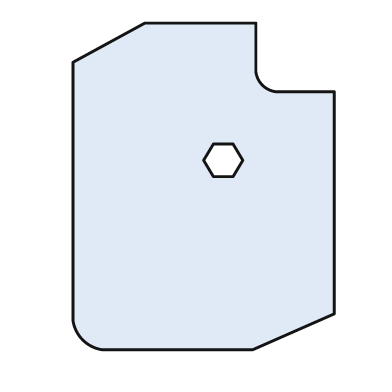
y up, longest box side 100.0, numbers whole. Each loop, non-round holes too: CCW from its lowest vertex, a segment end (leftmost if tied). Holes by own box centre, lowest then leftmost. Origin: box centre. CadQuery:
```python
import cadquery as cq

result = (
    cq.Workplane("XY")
    .moveTo(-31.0, -50.0)
    .lineTo(15.0, -50.0)
    .lineTo(40.0, -39.0)
    .lineTo(40.0, 29.0)
    .lineTo(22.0, 29.0)
    .threePointArc((18.0, 31.0), (16.0, 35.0))
    .lineTo(16.0, 50.0)
    .lineTo(-18.0, 50.0)
    .lineTo(-40.0, 38.0)
    .lineTo(-40.0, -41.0)
    .threePointArc((-37.0, -47.0), (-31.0, -50.0))
    .close()
    .moveTo(3.0, 3.0)
    .lineTo(9.0, 3.0)
    .lineTo(12.0, 8.0)
    .lineTo(9.0, 13.0)
    .lineTo(3.0, 13.0)
    .lineTo(0.0, 8.0)
    .close()
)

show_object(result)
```